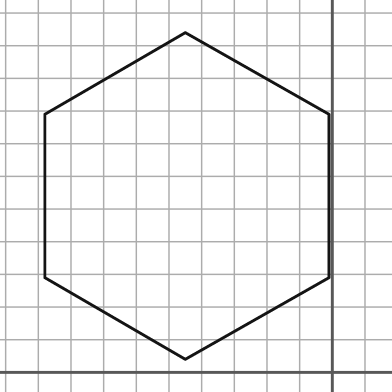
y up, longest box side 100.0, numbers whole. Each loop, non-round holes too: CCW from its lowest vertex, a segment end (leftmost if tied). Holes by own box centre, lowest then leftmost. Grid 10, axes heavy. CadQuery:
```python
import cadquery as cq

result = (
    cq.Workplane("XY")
    .moveTo(-45.0, 4.0)
    .lineTo(-1.0, 29.0)
    .lineTo(-1.0, 79.0)
    .lineTo(-45.0, 104.0)
    .lineTo(-88.0, 79.0)
    .lineTo(-88.0, 29.0)
    .close()
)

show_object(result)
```